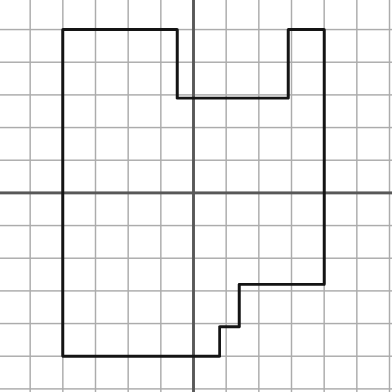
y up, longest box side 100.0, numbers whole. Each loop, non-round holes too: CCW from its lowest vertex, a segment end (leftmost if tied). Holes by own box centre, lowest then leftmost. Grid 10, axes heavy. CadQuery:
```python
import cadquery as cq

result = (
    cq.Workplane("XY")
    .moveTo(-40.0, -50.0)
    .lineTo(8.0, -50.0)
    .lineTo(8.0, -41.0)
    .lineTo(14.0, -41.0)
    .lineTo(14.0, -28.0)
    .lineTo(40.0, -28.0)
    .lineTo(40.0, 50.0)
    .lineTo(29.0, 50.0)
    .lineTo(29.0, 29.0)
    .lineTo(-5.0, 29.0)
    .lineTo(-5.0, 50.0)
    .lineTo(-40.0, 50.0)
    .close()
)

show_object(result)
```